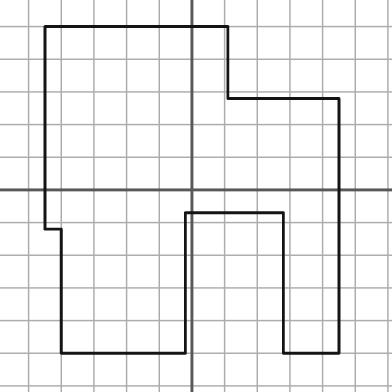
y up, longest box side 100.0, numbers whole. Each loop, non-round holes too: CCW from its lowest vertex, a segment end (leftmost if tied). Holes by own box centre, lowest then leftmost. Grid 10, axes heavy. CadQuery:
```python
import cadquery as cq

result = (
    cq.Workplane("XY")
    .moveTo(-40.0, -50.0)
    .lineTo(-2.0, -50.0)
    .lineTo(-2.0, -7.0)
    .lineTo(28.0, -7.0)
    .lineTo(28.0, -50.0)
    .lineTo(45.0, -50.0)
    .lineTo(45.0, 28.0)
    .lineTo(11.0, 28.0)
    .lineTo(11.0, 50.0)
    .lineTo(-45.0, 50.0)
    .lineTo(-45.0, -12.0)
    .lineTo(-40.0, -12.0)
    .close()
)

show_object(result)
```